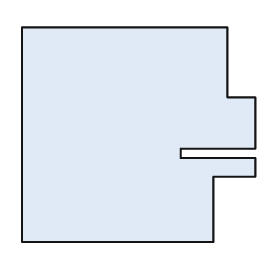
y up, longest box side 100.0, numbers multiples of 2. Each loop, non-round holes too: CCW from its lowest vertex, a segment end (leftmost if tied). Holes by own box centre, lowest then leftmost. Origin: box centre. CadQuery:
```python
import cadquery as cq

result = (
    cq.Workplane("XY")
    .moveTo(-50.0, -46.0)
    .lineTo(32.0, -46.0)
    .lineTo(32.0, -18.0)
    .lineTo(50.0, -18.0)
    .lineTo(50.0, -10.0)
    .lineTo(18.0, -10.0)
    .lineTo(18.0, -6.0)
    .lineTo(50.0, -6.0)
    .lineTo(50.0, 16.0)
    .lineTo(38.0, 16.0)
    .lineTo(38.0, 46.0)
    .lineTo(-50.0, 46.0)
    .close()
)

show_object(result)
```